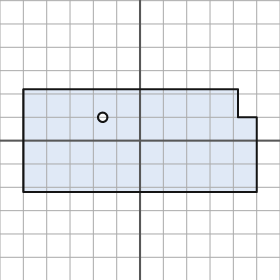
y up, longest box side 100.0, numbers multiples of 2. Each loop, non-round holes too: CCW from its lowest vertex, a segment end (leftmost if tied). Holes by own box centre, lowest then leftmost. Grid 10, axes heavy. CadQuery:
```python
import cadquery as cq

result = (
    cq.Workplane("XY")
    .moveTo(-50.0, -22.0)
    .lineTo(50.0, -22.0)
    .lineTo(50.0, 10.0)
    .lineTo(42.0, 10.0)
    .lineTo(42.0, 22.0)
    .lineTo(-50.0, 22.0)
    .close()
    .moveTo(-16.0, 10.0)
    .circle(2.0)
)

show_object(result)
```